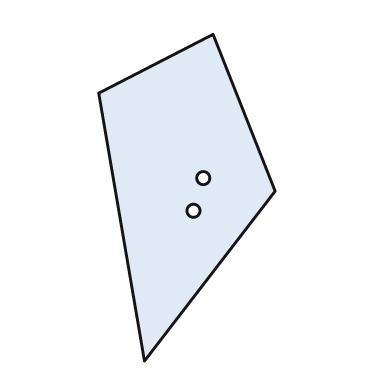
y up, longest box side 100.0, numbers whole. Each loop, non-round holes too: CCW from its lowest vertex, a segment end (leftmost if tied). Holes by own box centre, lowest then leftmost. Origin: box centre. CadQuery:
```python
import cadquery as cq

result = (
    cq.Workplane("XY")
    .moveTo(-13.0, -50.0)
    .lineTo(27.0, 2.0)
    .lineTo(8.0, 50.0)
    .lineTo(-27.0, 32.0)
    .close()
    .moveTo(2.0, -4.0)
    .circle(2.0)
    .moveTo(5.0, 6.0)
    .circle(2.0)
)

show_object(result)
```